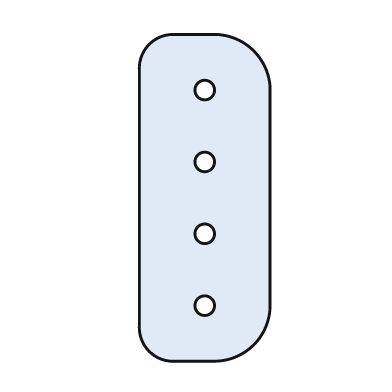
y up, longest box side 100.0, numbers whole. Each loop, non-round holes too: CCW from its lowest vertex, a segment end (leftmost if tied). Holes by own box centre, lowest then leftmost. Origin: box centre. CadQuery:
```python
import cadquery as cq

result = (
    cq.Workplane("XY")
    .moveTo(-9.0, -50.0)
    .lineTo(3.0, -50.0)
    .threePointArc((15.0, -45.0), (20.0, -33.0))
    .lineTo(20.0, 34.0)
    .threePointArc((15.0, 45.0), (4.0, 50.0))
    .lineTo(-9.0, 50.0)
    .threePointArc((-17.0, 47.0), (-20.0, 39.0))
    .lineTo(-20.0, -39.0)
    .threePointArc((-17.0, -47.0), (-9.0, -50.0))
    .close()
    .moveTo(0.0, -33.0)
    .circle(3.0)
    .moveTo(0.0, -11.0)
    .circle(3.0)
    .moveTo(0.0, 11.0)
    .circle(3.0)
    .moveTo(0.0, 33.0)
    .circle(3.0)
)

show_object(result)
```